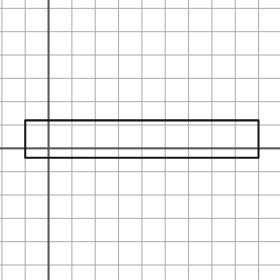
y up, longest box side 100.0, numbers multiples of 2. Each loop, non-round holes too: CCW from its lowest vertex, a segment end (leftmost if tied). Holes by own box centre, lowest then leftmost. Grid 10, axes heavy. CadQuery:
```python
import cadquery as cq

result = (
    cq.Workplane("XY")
    .moveTo(-10.0, -4.0)
    .lineTo(90.0, -4.0)
    .lineTo(90.0, 12.0)
    .lineTo(-10.0, 12.0)
    .close()
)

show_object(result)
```